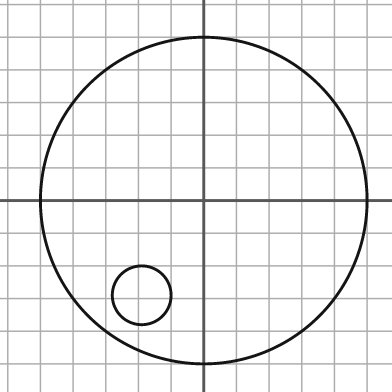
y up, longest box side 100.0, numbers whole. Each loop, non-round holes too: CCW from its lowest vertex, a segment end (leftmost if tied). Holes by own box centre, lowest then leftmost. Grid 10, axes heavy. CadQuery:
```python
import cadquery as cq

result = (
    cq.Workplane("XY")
    .moveTo(0.0, 0.0)
    .circle(50.0)
    .moveTo(-19.0, -29.0)
    .circle(9.0)
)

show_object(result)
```